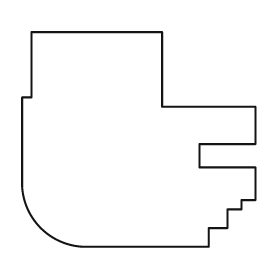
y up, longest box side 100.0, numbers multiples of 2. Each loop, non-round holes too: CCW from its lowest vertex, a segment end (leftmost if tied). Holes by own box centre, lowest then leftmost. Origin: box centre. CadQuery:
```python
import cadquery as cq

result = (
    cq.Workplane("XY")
    .moveTo(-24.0, -46.0)
    .lineTo(30.0, -46.0)
    .lineTo(30.0, -38.0)
    .lineTo(38.0, -38.0)
    .lineTo(38.0, -30.0)
    .lineTo(44.0, -30.0)
    .lineTo(44.0, -26.0)
    .lineTo(50.0, -26.0)
    .lineTo(50.0, -12.0)
    .lineTo(26.0, -12.0)
    .lineTo(26.0, -2.0)
    .lineTo(50.0, -2.0)
    .lineTo(50.0, 14.0)
    .lineTo(10.0, 14.0)
    .lineTo(10.0, 46.0)
    .lineTo(-46.0, 46.0)
    .lineTo(-46.0, 18.0)
    .lineTo(-50.0, 18.0)
    .lineTo(-50.0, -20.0)
    .threePointArc((-42.0, -38.0), (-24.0, -46.0))
    .close()
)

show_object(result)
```